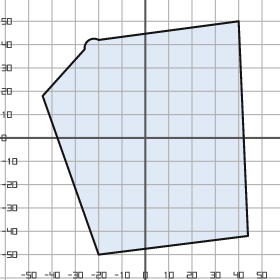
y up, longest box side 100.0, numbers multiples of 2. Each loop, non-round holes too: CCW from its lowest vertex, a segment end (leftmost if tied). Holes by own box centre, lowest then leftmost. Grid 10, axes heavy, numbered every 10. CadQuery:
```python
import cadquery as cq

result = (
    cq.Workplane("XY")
    .moveTo(-20.0, -50.0)
    .lineTo(44.0, -42.0)
    .lineTo(40.0, 50.0)
    .lineTo(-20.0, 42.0)
    .threePointArc((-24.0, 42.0), (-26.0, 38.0))
    .lineTo(-44.0, 18.0)
    .close()
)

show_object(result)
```